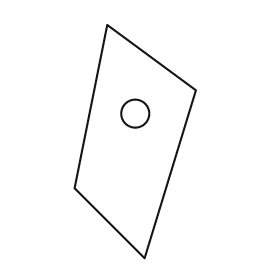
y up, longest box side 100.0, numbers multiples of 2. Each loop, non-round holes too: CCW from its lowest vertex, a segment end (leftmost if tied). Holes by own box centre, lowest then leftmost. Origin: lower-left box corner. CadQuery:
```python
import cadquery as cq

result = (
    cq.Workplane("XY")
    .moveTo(30.0, 0.0)
    .lineTo(52.0, 72.0)
    .lineTo(14.0, 100.0)
    .lineTo(0.0, 30.0)
    .close()
    .moveTo(26.0, 62.0)
    .circle(6.0)
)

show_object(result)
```